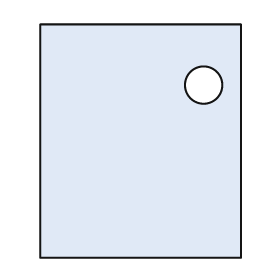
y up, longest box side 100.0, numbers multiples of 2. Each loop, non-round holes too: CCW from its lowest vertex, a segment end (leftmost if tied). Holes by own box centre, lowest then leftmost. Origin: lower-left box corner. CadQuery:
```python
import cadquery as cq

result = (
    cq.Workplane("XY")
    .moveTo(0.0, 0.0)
    .lineTo(86.0, 0.0)
    .lineTo(86.0, 100.0)
    .lineTo(0.0, 100.0)
    .close()
    .moveTo(70.0, 74.0)
    .circle(8.0)
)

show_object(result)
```